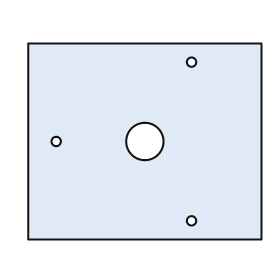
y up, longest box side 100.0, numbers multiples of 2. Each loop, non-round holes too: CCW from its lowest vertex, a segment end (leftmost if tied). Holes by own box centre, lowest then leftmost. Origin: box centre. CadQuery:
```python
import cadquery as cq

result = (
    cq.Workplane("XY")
    .moveTo(-50.0, -42.0)
    .lineTo(50.0, -42.0)
    .lineTo(50.0, 42.0)
    .lineTo(-50.0, 42.0)
    .close()
    .moveTo(20.0, -34.0)
    .circle(2.0)
    .moveTo(-38.0, 0.0)
    .circle(2.0)
    .moveTo(0.0, 0.0)
    .circle(8.0)
    .moveTo(20.0, 34.0)
    .circle(2.0)
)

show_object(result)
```